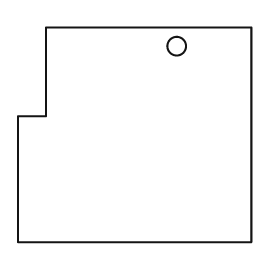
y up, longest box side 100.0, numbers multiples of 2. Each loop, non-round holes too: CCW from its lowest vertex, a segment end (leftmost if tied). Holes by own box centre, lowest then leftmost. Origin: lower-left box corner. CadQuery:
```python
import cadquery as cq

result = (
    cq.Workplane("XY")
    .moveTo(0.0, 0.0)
    .lineTo(100.0, 0.0)
    .lineTo(100.0, 92.0)
    .lineTo(12.0, 92.0)
    .lineTo(12.0, 54.0)
    .lineTo(0.0, 54.0)
    .close()
    .moveTo(68.0, 84.0)
    .circle(4.0)
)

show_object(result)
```